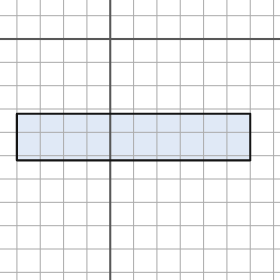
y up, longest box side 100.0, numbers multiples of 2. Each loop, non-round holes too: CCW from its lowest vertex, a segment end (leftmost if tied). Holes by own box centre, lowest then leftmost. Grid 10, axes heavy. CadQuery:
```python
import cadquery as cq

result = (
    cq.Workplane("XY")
    .moveTo(-40.0, -52.0)
    .lineTo(60.0, -52.0)
    .lineTo(60.0, -32.0)
    .lineTo(-40.0, -32.0)
    .close()
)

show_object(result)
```